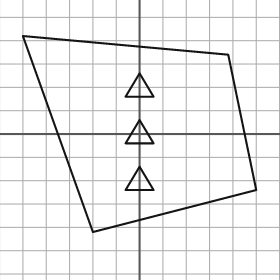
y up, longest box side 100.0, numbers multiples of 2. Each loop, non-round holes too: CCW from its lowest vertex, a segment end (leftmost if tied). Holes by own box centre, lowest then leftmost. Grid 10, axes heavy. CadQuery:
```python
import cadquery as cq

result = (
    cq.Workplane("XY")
    .moveTo(-20.0, -42.0)
    .lineTo(50.0, -24.0)
    .lineTo(38.0, 34.0)
    .lineTo(-50.0, 42.0)
    .close()
    .moveTo(-6.0, -24.0)
    .lineTo(6.0, -24.0)
    .lineTo(0.0, -14.0)
    .close()
    .moveTo(-6.0, -4.0)
    .lineTo(6.0, -4.0)
    .lineTo(0.0, 6.0)
    .close()
    .moveTo(-6.0, 16.0)
    .lineTo(6.0, 16.0)
    .lineTo(0.0, 26.0)
    .close()
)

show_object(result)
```